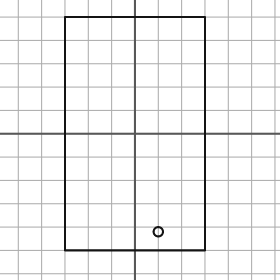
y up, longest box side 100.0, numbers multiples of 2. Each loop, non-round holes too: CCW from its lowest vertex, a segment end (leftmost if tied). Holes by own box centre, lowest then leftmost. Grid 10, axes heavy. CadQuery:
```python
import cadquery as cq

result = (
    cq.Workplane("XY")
    .moveTo(-30.0, -50.0)
    .lineTo(30.0, -50.0)
    .lineTo(30.0, 50.0)
    .lineTo(-30.0, 50.0)
    .close()
    .moveTo(10.0, -42.0)
    .circle(2.0)
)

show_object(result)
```